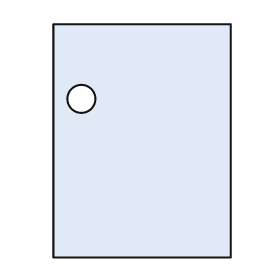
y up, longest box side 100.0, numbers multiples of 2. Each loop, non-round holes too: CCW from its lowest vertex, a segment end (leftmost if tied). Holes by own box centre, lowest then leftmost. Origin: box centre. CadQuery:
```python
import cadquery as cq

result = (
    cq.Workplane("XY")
    .moveTo(-38.0, -50.0)
    .lineTo(38.0, -50.0)
    .lineTo(38.0, 50.0)
    .lineTo(-38.0, 50.0)
    .close()
    .moveTo(-26.0, 18.0)
    .circle(6.0)
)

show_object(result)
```